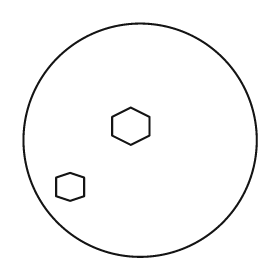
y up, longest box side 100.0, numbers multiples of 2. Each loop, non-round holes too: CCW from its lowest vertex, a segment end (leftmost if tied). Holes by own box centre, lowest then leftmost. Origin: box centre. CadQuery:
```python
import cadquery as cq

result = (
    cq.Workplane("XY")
    .moveTo(0.0, 0.0)
    .circle(50.0)
    .moveTo(-30.0, -26.0)
    .lineTo(-24.0, -24.0)
    .lineTo(-24.0, -16.0)
    .lineTo(-30.0, -14.0)
    .lineTo(-36.0, -16.0)
    .lineTo(-36.0, -24.0)
    .close()
    .moveTo(-4.0, -2.0)
    .lineTo(4.0, 2.0)
    .lineTo(4.0, 10.0)
    .lineTo(-4.0, 14.0)
    .lineTo(-12.0, 10.0)
    .lineTo(-12.0, 2.0)
    .close()
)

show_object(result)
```